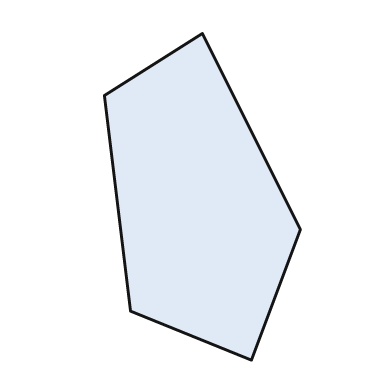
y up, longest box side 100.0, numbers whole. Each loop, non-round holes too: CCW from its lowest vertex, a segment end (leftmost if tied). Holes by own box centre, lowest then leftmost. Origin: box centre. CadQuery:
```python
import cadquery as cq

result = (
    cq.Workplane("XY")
    .moveTo(15.0, -50.0)
    .lineTo(30.0, -10.0)
    .lineTo(0.0, 50.0)
    .lineTo(-30.0, 31.0)
    .lineTo(-22.0, -35.0)
    .close()
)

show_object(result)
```